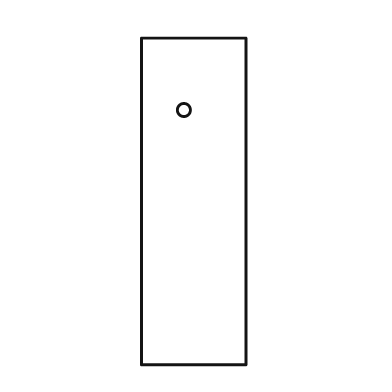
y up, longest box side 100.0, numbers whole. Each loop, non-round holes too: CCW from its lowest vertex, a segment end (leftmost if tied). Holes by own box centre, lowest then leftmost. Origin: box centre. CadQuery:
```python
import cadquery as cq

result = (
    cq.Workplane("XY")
    .moveTo(-16.0, -50.0)
    .lineTo(16.0, -50.0)
    .lineTo(16.0, 50.0)
    .lineTo(-16.0, 50.0)
    .close()
    .moveTo(-3.0, 28.0)
    .circle(2.0)
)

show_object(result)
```